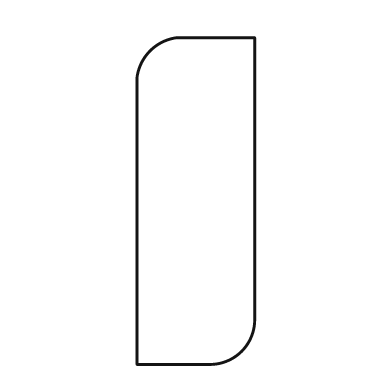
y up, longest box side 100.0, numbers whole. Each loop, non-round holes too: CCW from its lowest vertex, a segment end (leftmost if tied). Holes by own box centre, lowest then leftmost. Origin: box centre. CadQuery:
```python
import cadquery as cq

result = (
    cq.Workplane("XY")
    .moveTo(-18.0, -50.0)
    .lineTo(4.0, -50.0)
    .threePointArc((14.0, -46.0), (18.0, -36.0))
    .lineTo(18.0, 50.0)
    .lineTo(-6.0, 50.0)
    .threePointArc((-14.0, 46.0), (-18.0, 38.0))
    .close()
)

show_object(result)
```